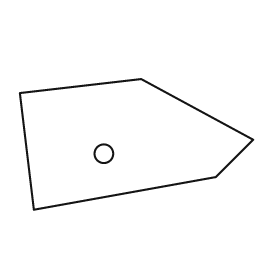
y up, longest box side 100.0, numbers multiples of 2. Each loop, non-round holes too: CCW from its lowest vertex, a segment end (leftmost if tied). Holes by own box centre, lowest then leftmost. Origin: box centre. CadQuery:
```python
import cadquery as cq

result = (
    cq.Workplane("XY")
    .moveTo(-44.0, -28.0)
    .lineTo(34.0, -14.0)
    .lineTo(50.0, 2.0)
    .lineTo(2.0, 28.0)
    .lineTo(-50.0, 22.0)
    .close()
    .moveTo(-14.0, -4.0)
    .circle(4.0)
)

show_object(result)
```